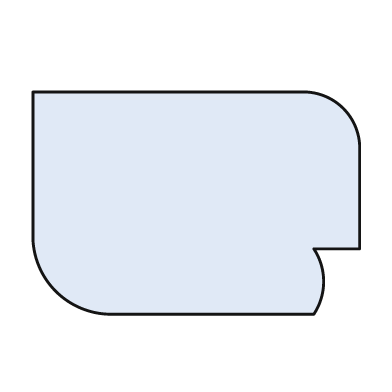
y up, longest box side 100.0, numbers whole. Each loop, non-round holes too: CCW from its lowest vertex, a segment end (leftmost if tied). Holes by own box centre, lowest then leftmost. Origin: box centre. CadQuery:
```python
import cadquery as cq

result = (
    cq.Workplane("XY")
    .moveTo(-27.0, -34.0)
    .lineTo(36.0, -34.0)
    .threePointArc((39.0, -24.0), (36.0, -14.0))
    .lineTo(50.0, -14.0)
    .lineTo(50.0, 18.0)
    .threePointArc((45.0, 29.0), (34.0, 34.0))
    .lineTo(-50.0, 34.0)
    .lineTo(-50.0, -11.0)
    .threePointArc((-43.0, -27.0), (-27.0, -34.0))
    .close()
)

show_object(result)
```